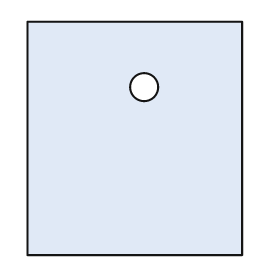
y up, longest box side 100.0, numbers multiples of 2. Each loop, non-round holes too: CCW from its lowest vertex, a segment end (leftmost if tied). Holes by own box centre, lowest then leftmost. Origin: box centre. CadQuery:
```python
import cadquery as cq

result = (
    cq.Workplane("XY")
    .moveTo(-46.0, -50.0)
    .lineTo(46.0, -50.0)
    .lineTo(46.0, 50.0)
    .lineTo(-46.0, 50.0)
    .close()
    .moveTo(4.0, 22.0)
    .circle(6.0)
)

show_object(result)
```